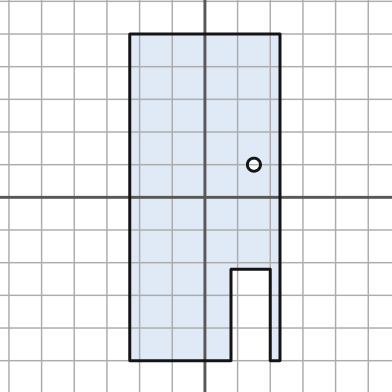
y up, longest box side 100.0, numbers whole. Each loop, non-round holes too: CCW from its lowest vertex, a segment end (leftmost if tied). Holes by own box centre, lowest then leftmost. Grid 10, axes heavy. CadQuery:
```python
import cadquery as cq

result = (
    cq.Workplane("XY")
    .moveTo(-23.0, -50.0)
    .lineTo(8.0, -50.0)
    .lineTo(8.0, -22.0)
    .lineTo(20.0, -22.0)
    .lineTo(20.0, -50.0)
    .lineTo(23.0, -50.0)
    .lineTo(23.0, 50.0)
    .lineTo(-23.0, 50.0)
    .close()
    .moveTo(15.0, 10.0)
    .circle(2.0)
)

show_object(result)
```